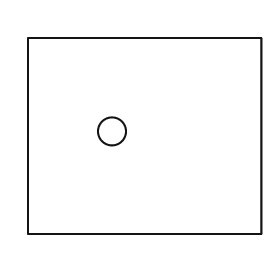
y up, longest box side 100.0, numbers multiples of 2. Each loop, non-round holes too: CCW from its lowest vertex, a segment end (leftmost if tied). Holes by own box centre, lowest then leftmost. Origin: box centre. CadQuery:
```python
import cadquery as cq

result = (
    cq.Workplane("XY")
    .moveTo(-50.0, -42.0)
    .lineTo(50.0, -42.0)
    .lineTo(50.0, 42.0)
    .lineTo(-50.0, 42.0)
    .close()
    .moveTo(-14.0, 2.0)
    .circle(6.0)
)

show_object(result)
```